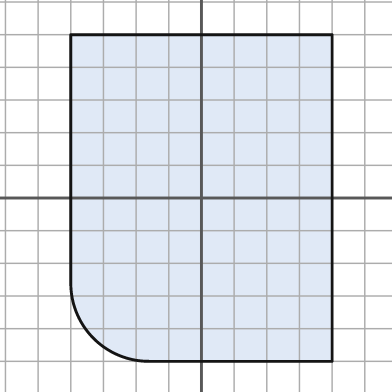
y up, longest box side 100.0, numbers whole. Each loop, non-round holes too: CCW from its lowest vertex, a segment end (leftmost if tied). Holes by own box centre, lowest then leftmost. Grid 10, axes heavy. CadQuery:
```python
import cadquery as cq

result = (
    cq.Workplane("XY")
    .moveTo(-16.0, -50.0)
    .lineTo(40.0, -50.0)
    .lineTo(40.0, 50.0)
    .lineTo(-40.0, 50.0)
    .lineTo(-40.0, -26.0)
    .threePointArc((-33.0, -43.0), (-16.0, -50.0))
    .close()
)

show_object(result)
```